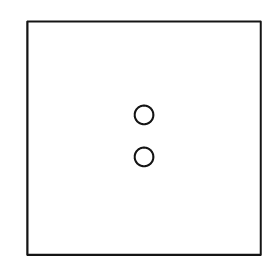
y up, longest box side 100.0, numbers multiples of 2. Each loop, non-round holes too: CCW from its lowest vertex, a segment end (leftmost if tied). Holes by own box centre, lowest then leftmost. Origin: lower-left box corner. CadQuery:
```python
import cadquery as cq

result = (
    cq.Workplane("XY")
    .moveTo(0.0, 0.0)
    .lineTo(100.0, 0.0)
    .lineTo(100.0, 100.0)
    .lineTo(0.0, 100.0)
    .close()
    .moveTo(50.0, 42.0)
    .circle(4.0)
    .moveTo(50.0, 60.0)
    .circle(4.0)
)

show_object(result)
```